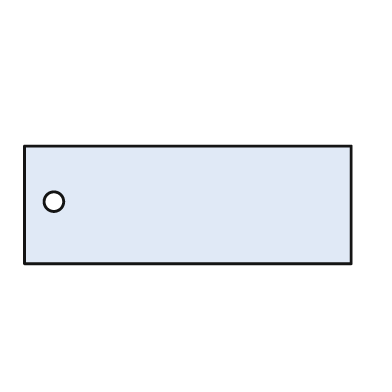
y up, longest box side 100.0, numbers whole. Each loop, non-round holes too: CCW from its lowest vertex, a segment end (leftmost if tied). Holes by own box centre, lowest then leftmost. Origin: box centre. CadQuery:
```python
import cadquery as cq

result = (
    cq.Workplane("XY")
    .moveTo(-50.0, -18.0)
    .lineTo(50.0, -18.0)
    .lineTo(50.0, 18.0)
    .lineTo(-50.0, 18.0)
    .close()
    .moveTo(-41.0, 1.0)
    .circle(3.0)
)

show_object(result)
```